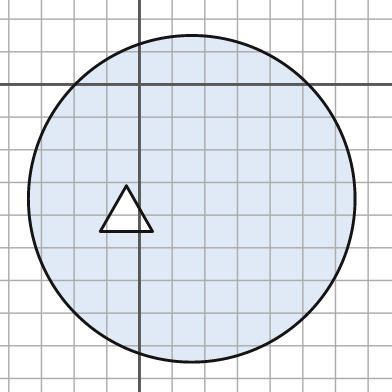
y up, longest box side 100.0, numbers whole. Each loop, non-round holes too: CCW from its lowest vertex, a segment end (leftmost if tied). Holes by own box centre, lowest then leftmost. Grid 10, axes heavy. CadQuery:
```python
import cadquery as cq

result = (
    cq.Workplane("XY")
    .moveTo(16.0, -35.0)
    .circle(50.0)
    .moveTo(-12.0, -45.0)
    .lineTo(4.0, -45.0)
    .lineTo(-4.0, -31.0)
    .close()
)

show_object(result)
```